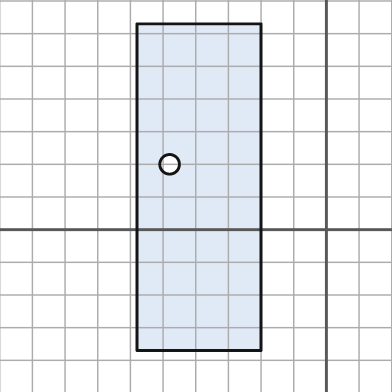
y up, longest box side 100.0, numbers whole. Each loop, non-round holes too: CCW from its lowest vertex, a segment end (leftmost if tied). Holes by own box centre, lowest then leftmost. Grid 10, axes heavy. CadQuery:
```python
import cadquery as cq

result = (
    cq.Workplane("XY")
    .moveTo(-58.0, -37.0)
    .lineTo(-20.0, -37.0)
    .lineTo(-20.0, 63.0)
    .lineTo(-58.0, 63.0)
    .close()
    .moveTo(-48.0, 20.0)
    .circle(3.0)
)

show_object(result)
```